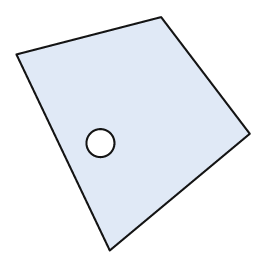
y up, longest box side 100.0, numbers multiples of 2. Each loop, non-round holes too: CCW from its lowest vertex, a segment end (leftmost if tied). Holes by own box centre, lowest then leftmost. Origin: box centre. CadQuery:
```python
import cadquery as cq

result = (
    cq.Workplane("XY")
    .moveTo(-10.0, -50.0)
    .lineTo(50.0, 0.0)
    .lineTo(12.0, 50.0)
    .lineTo(-50.0, 34.0)
    .close()
    .moveTo(-14.0, -4.0)
    .circle(6.0)
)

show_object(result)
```